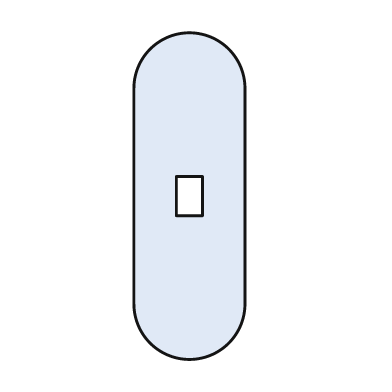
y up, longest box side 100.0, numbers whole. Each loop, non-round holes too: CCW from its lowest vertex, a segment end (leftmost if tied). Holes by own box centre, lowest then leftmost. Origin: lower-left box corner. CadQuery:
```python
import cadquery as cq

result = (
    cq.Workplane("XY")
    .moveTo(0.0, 17.0)
    .threePointArc((17.0, 0.0), (34.0, 17.0))
    .lineTo(34.0, 83.0)
    .threePointArc((17.0, 100.0), (0.0, 83.0))
    .close()
    .moveTo(13.0, 44.0)
    .lineTo(21.0, 44.0)
    .lineTo(21.0, 56.0)
    .lineTo(13.0, 56.0)
    .close()
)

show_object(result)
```